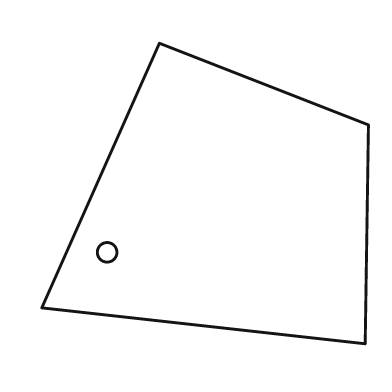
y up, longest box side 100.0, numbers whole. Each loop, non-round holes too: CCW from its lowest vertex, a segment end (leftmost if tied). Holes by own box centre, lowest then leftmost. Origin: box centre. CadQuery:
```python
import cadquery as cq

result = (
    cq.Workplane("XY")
    .moveTo(49.0, -46.0)
    .lineTo(50.0, 21.0)
    .lineTo(-14.0, 46.0)
    .lineTo(-50.0, -35.0)
    .close()
    .moveTo(-30.0, -18.0)
    .circle(3.0)
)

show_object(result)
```